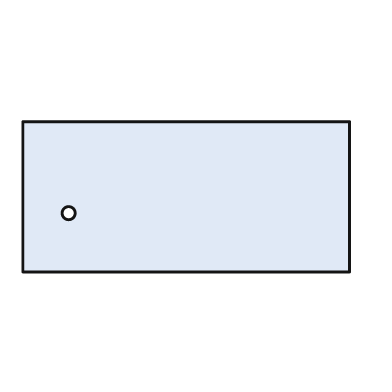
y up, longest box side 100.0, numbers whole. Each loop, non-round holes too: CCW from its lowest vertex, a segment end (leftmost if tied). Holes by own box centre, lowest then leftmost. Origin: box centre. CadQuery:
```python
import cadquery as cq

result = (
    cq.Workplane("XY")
    .moveTo(-50.0, -23.0)
    .lineTo(50.0, -23.0)
    .lineTo(50.0, 23.0)
    .lineTo(-50.0, 23.0)
    .close()
    .moveTo(-36.0, -5.0)
    .circle(2.0)
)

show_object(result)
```